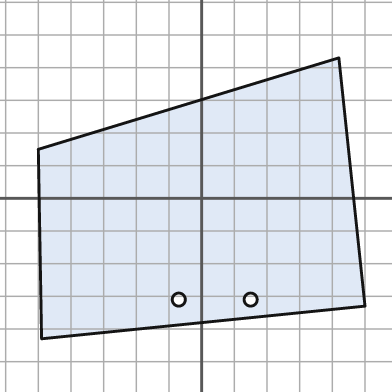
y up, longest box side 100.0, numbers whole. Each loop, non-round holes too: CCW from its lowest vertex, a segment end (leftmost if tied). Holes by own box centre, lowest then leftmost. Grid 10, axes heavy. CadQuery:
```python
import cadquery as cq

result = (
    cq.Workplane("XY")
    .moveTo(-49.0, -43.0)
    .lineTo(50.0, -33.0)
    .lineTo(42.0, 43.0)
    .lineTo(-50.0, 15.0)
    .close()
    .moveTo(-7.0, -31.0)
    .circle(2.0)
    .moveTo(15.0, -31.0)
    .circle(2.0)
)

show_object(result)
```